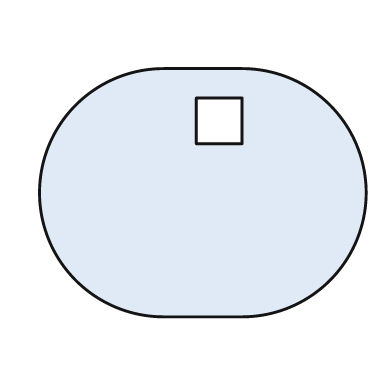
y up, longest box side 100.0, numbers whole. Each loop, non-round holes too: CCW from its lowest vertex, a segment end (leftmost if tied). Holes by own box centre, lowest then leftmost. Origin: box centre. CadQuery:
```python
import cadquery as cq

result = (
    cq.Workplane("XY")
    .moveTo(-12.0, -38.0)
    .lineTo(12.0, -38.0)
    .threePointArc((50.0, 0.0), (12.0, 38.0))
    .lineTo(-12.0, 38.0)
    .threePointArc((-50.0, 0.0), (-12.0, -38.0))
    .close()
    .moveTo(-2.0, 15.0)
    .lineTo(12.0, 15.0)
    .lineTo(12.0, 29.0)
    .lineTo(-2.0, 29.0)
    .close()
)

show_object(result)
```